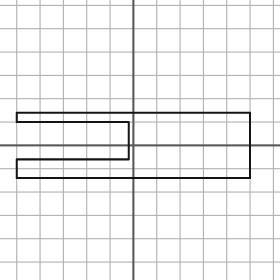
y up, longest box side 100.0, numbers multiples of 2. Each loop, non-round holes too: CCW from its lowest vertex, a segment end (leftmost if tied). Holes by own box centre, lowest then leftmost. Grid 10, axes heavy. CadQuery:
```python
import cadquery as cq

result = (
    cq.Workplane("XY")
    .moveTo(-50.0, -14.0)
    .lineTo(50.0, -14.0)
    .lineTo(50.0, 14.0)
    .lineTo(-50.0, 14.0)
    .lineTo(-50.0, 10.0)
    .lineTo(-2.0, 10.0)
    .lineTo(-2.0, -6.0)
    .lineTo(-50.0, -6.0)
    .close()
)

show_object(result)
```